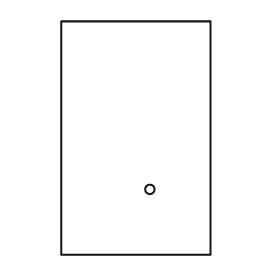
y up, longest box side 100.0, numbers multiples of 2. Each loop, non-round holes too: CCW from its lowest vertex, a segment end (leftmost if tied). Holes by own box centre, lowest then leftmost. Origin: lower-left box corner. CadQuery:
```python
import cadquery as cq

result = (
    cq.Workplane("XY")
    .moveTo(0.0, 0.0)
    .lineTo(64.0, 0.0)
    .lineTo(64.0, 100.0)
    .lineTo(0.0, 100.0)
    .close()
    .moveTo(38.0, 28.0)
    .circle(2.0)
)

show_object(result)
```